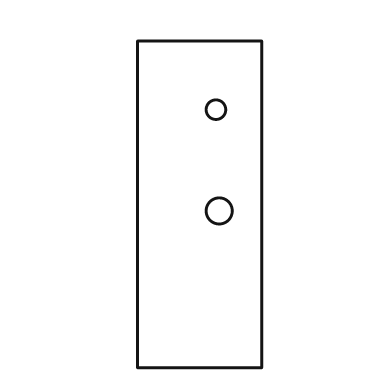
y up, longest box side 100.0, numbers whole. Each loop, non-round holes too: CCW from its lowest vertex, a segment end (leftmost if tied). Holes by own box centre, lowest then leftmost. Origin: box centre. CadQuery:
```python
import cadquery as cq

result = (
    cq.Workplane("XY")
    .moveTo(-19.0, -50.0)
    .lineTo(19.0, -50.0)
    .lineTo(19.0, 50.0)
    .lineTo(-19.0, 50.0)
    .close()
    .moveTo(6.0, -2.0)
    .circle(4.0)
    .moveTo(5.0, 29.0)
    .circle(3.0)
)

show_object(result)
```